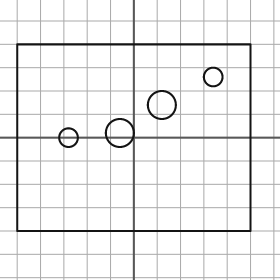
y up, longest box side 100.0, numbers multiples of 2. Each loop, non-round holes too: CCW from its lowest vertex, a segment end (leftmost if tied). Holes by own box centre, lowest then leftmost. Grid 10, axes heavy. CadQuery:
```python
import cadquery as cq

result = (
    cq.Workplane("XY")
    .moveTo(-50.0, -40.0)
    .lineTo(50.0, -40.0)
    .lineTo(50.0, 40.0)
    .lineTo(-50.0, 40.0)
    .close()
    .moveTo(-28.0, 0.0)
    .circle(4.0)
    .moveTo(-6.0, 2.0)
    .circle(6.0)
    .moveTo(12.0, 14.0)
    .circle(6.0)
    .moveTo(34.0, 26.0)
    .circle(4.0)
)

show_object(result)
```